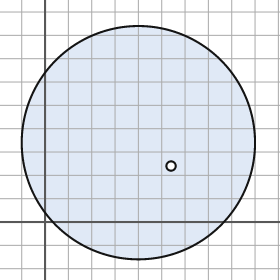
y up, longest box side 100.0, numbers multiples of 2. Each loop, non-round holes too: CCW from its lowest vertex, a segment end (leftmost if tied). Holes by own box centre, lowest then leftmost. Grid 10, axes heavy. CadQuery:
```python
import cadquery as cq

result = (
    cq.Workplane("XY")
    .moveTo(40.0, 34.0)
    .circle(50.0)
    .moveTo(54.0, 24.0)
    .circle(2.0)
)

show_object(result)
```